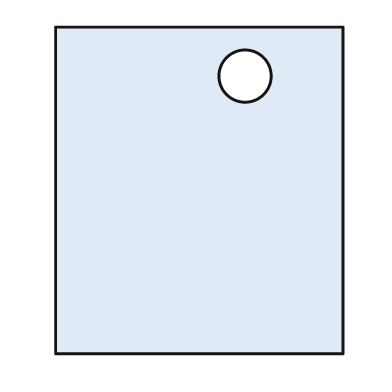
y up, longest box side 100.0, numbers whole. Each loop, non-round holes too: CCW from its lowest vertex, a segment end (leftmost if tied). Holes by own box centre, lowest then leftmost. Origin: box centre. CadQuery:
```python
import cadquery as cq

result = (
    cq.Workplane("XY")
    .moveTo(-44.0, -50.0)
    .lineTo(44.0, -50.0)
    .lineTo(44.0, 50.0)
    .lineTo(-44.0, 50.0)
    .close()
    .moveTo(14.0, 35.0)
    .circle(8.0)
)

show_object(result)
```